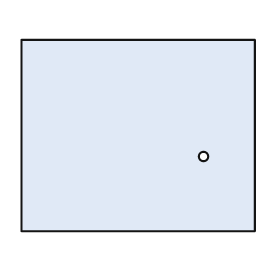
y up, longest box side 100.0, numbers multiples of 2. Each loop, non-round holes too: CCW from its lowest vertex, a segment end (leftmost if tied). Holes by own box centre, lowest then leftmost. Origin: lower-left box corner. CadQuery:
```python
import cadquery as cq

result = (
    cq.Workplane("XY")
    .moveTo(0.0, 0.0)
    .lineTo(100.0, 0.0)
    .lineTo(100.0, 82.0)
    .lineTo(0.0, 82.0)
    .close()
    .moveTo(78.0, 32.0)
    .circle(2.0)
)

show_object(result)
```